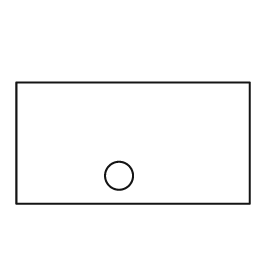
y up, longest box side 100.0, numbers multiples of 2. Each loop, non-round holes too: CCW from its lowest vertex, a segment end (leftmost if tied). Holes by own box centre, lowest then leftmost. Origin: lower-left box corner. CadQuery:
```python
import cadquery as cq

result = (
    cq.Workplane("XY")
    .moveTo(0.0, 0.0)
    .lineTo(100.0, 0.0)
    .lineTo(100.0, 52.0)
    .lineTo(0.0, 52.0)
    .close()
    .moveTo(44.0, 12.0)
    .circle(6.0)
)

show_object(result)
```